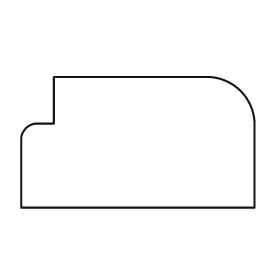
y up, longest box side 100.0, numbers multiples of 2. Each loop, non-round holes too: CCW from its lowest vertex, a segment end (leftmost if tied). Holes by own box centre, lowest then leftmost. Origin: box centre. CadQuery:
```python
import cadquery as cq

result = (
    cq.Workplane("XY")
    .moveTo(-50.0, -28.0)
    .lineTo(50.0, -28.0)
    .lineTo(50.0, 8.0)
    .threePointArc((44.0, 22.0), (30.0, 28.0))
    .lineTo(-36.0, 28.0)
    .lineTo(-36.0, 8.0)
    .lineTo(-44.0, 8.0)
    .threePointArc((-48.0, 6.0), (-50.0, 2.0))
    .close()
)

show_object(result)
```